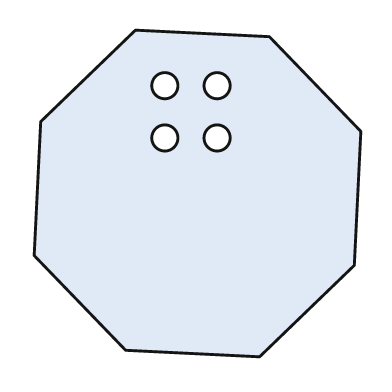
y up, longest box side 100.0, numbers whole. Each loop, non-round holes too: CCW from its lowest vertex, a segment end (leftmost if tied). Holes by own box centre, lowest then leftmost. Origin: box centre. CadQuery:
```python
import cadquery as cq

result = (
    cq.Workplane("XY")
    .moveTo(19.0, -50.0)
    .lineTo(48.0, -22.0)
    .lineTo(50.0, 19.0)
    .lineTo(22.0, 48.0)
    .lineTo(-19.0, 50.0)
    .lineTo(-48.0, 22.0)
    .lineTo(-50.0, -19.0)
    .lineTo(-22.0, -48.0)
    .close()
    .moveTo(-10.0, 17.0)
    .circle(4.0)
    .moveTo(6.0, 17.0)
    .circle(4.0)
    .moveTo(-10.0, 33.0)
    .circle(4.0)
    .moveTo(6.0, 33.0)
    .circle(4.0)
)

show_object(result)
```